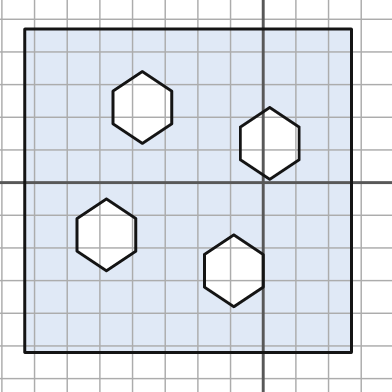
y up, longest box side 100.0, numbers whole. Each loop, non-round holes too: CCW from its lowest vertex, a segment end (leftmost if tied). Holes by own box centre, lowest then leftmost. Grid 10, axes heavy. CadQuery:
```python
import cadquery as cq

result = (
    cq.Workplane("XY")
    .moveTo(-73.0, -52.0)
    .lineTo(27.0, -52.0)
    .lineTo(27.0, 47.0)
    .lineTo(-73.0, 47.0)
    .close()
    .moveTo(-9.0, -38.0)
    .lineTo(0.0, -32.0)
    .lineTo(0.0, -22.0)
    .lineTo(-9.0, -16.0)
    .lineTo(-18.0, -22.0)
    .lineTo(-18.0, -32.0)
    .close()
    .moveTo(-48.0, -27.0)
    .lineTo(-39.0, -21.0)
    .lineTo(-39.0, -11.0)
    .lineTo(-48.0, -5.0)
    .lineTo(-57.0, -11.0)
    .lineTo(-57.0, -21.0)
    .close()
    .moveTo(2.0, 1.0)
    .lineTo(11.0, 7.0)
    .lineTo(11.0, 17.0)
    .lineTo(2.0, 23.0)
    .lineTo(-7.0, 17.0)
    .lineTo(-7.0, 7.0)
    .close()
    .moveTo(-37.0, 12.0)
    .lineTo(-28.0, 18.0)
    .lineTo(-28.0, 28.0)
    .lineTo(-37.0, 34.0)
    .lineTo(-46.0, 28.0)
    .lineTo(-46.0, 18.0)
    .close()
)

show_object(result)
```